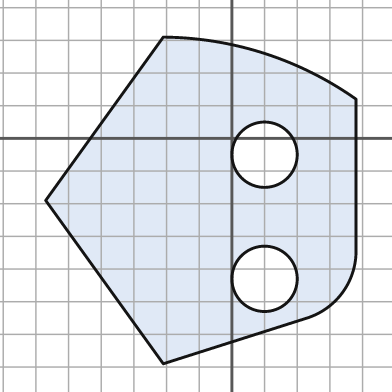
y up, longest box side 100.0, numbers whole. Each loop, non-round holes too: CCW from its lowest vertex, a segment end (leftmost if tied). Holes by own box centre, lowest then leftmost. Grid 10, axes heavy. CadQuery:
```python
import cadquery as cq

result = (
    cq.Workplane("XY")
    .moveTo(-21.0, -69.0)
    .lineTo(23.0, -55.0)
    .threePointArc((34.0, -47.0), (38.0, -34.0))
    .lineTo(38.0, 12.0)
    .threePointArc((10.0, 26.0), (-21.0, 31.0))
    .lineTo(-57.0, -19.0)
    .close()
    .moveTo(10.0, -43.0)
    .circle(10.0)
    .moveTo(10.0, -5.0)
    .circle(10.0)
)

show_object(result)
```